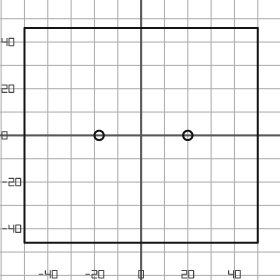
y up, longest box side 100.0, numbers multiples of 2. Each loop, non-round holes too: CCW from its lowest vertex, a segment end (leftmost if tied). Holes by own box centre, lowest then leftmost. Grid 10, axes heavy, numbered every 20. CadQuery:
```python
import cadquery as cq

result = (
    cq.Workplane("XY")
    .moveTo(-50.0, -46.0)
    .lineTo(50.0, -46.0)
    .lineTo(50.0, 46.0)
    .lineTo(-50.0, 46.0)
    .close()
    .moveTo(-18.0, 0.0)
    .circle(2.0)
    .moveTo(20.0, 0.0)
    .circle(2.0)
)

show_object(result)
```